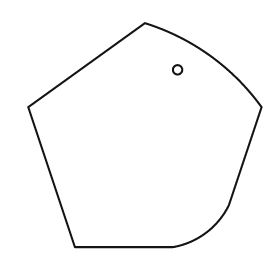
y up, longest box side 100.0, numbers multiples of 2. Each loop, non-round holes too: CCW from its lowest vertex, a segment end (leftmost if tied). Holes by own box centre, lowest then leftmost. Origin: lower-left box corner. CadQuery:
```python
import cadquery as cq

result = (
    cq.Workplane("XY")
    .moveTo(20.0, 0.0)
    .lineTo(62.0, 0.0)
    .threePointArc((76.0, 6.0), (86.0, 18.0))
    .lineTo(100.0, 60.0)
    .threePointArc((78.0, 82.0), (50.0, 96.0))
    .lineTo(0.0, 60.0)
    .close()
    .moveTo(64.0, 76.0)
    .circle(2.0)
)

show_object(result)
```